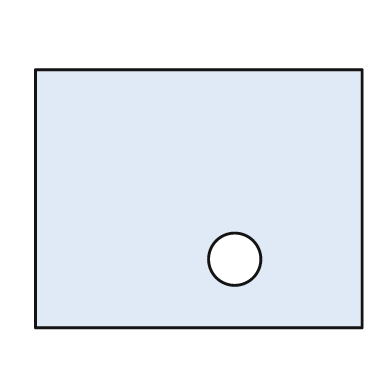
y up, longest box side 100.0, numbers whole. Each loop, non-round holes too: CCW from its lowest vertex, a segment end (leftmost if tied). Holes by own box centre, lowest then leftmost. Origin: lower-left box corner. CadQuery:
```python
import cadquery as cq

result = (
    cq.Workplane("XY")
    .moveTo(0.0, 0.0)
    .lineTo(100.0, 0.0)
    .lineTo(100.0, 79.0)
    .lineTo(0.0, 79.0)
    .close()
    .moveTo(61.0, 21.0)
    .circle(8.0)
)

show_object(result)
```